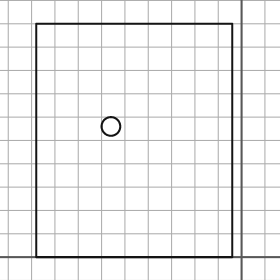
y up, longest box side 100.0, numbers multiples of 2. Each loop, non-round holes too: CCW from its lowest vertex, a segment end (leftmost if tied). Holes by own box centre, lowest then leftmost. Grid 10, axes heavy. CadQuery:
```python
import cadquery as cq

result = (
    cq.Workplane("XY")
    .moveTo(-88.0, 0.0)
    .lineTo(-4.0, 0.0)
    .lineTo(-4.0, 100.0)
    .lineTo(-88.0, 100.0)
    .close()
    .moveTo(-56.0, 56.0)
    .circle(4.0)
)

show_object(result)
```